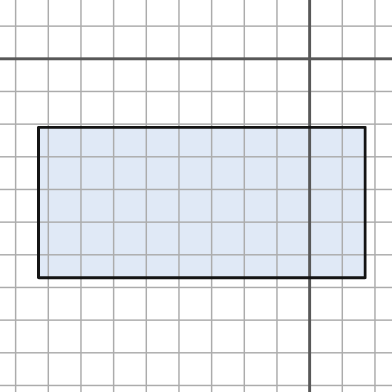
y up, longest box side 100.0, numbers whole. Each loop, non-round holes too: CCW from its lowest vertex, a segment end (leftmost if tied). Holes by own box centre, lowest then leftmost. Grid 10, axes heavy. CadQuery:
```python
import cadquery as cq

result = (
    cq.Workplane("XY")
    .moveTo(-83.0, -67.0)
    .lineTo(17.0, -67.0)
    .lineTo(17.0, -21.0)
    .lineTo(-83.0, -21.0)
    .close()
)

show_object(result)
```